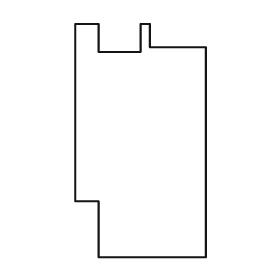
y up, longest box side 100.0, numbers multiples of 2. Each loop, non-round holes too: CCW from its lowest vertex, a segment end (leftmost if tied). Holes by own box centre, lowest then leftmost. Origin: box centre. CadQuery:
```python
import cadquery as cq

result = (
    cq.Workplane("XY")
    .moveTo(-18.0, -50.0)
    .lineTo(28.0, -50.0)
    .lineTo(28.0, 40.0)
    .lineTo(4.0, 40.0)
    .lineTo(4.0, 50.0)
    .lineTo(0.0, 50.0)
    .lineTo(0.0, 38.0)
    .lineTo(-18.0, 38.0)
    .lineTo(-18.0, 50.0)
    .lineTo(-28.0, 50.0)
    .lineTo(-28.0, -26.0)
    .lineTo(-18.0, -26.0)
    .close()
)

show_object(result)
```